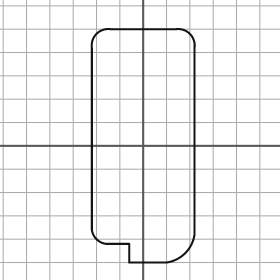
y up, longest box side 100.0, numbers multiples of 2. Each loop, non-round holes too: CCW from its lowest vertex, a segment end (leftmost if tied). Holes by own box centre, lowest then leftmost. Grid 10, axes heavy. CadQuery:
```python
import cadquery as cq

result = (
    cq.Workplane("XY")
    .moveTo(-6.0, -50.0)
    .lineTo(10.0, -50.0)
    .threePointArc((18.0, -46.0), (22.0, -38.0))
    .lineTo(22.0, 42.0)
    .threePointArc((20.0, 48.0), (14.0, 50.0))
    .lineTo(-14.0, 50.0)
    .threePointArc((-20.0, 48.0), (-22.0, 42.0))
    .lineTo(-22.0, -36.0)
    .threePointArc((-20.0, -40.0), (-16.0, -42.0))
    .lineTo(-6.0, -42.0)
    .close()
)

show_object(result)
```